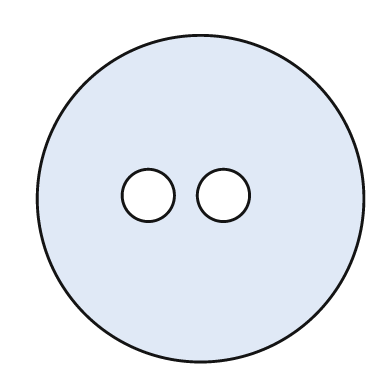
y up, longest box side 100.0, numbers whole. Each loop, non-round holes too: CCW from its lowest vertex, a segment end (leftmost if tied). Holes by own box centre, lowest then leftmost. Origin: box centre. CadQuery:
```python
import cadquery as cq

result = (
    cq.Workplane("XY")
    .moveTo(0.0, 0.0)
    .circle(50.0)
    .moveTo(-16.0, 1.0)
    .circle(8.0)
    .moveTo(7.0, 1.0)
    .circle(8.0)
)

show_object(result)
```